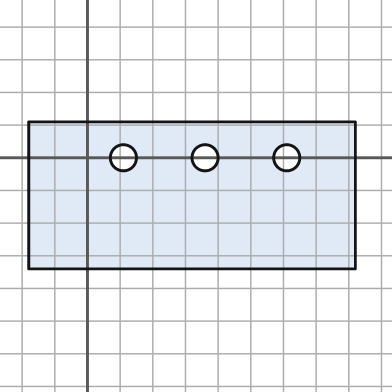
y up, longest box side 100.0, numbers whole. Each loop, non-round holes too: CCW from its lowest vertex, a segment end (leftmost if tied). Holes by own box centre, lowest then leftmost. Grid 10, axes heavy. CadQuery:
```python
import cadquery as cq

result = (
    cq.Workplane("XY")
    .moveTo(-18.0, -34.0)
    .lineTo(82.0, -34.0)
    .lineTo(82.0, 11.0)
    .lineTo(-18.0, 11.0)
    .close()
    .moveTo(11.0, 0.0)
    .circle(4.0)
    .moveTo(36.0, 0.0)
    .circle(4.0)
    .moveTo(61.0, 0.0)
    .circle(4.0)
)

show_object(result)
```